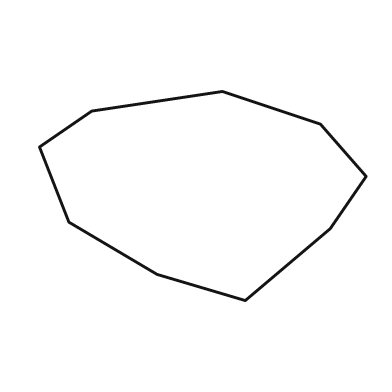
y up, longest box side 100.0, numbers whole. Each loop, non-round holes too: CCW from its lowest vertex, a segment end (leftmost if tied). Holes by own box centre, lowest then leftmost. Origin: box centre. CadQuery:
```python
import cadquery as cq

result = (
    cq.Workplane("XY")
    .moveTo(13.0, -32.0)
    .lineTo(39.0, -10.0)
    .lineTo(50.0, 6.0)
    .lineTo(36.0, 22.0)
    .lineTo(6.0, 32.0)
    .lineTo(-34.0, 26.0)
    .lineTo(-50.0, 15.0)
    .lineTo(-41.0, -8.0)
    .lineTo(-14.0, -24.0)
    .close()
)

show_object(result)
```